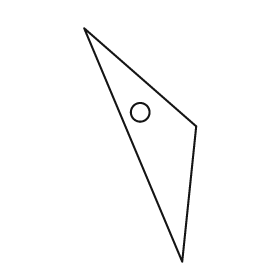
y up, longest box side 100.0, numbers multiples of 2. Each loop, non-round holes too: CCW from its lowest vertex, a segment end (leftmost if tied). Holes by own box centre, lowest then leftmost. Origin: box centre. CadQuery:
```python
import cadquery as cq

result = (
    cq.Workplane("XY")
    .moveTo(18.0, -50.0)
    .lineTo(24.0, 8.0)
    .lineTo(-24.0, 50.0)
    .close()
    .moveTo(0.0, 14.0)
    .circle(4.0)
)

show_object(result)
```